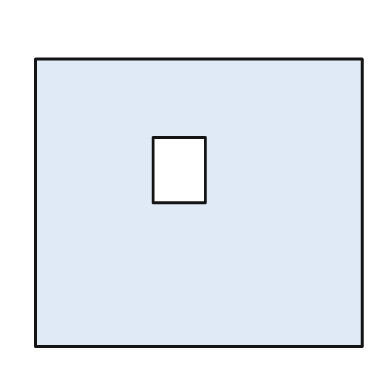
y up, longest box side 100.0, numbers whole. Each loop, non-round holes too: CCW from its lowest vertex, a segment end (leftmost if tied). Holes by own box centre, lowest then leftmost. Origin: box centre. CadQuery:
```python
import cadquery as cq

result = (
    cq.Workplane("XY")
    .moveTo(-50.0, -44.0)
    .lineTo(50.0, -44.0)
    .lineTo(50.0, 44.0)
    .lineTo(-50.0, 44.0)
    .close()
    .moveTo(-14.0, 0.0)
    .lineTo(2.0, 0.0)
    .lineTo(2.0, 20.0)
    .lineTo(-14.0, 20.0)
    .close()
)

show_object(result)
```